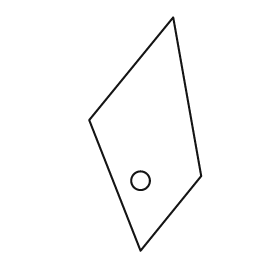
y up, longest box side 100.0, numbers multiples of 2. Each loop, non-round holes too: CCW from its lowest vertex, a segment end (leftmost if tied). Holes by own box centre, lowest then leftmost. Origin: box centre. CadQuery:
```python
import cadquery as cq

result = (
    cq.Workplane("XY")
    .moveTo(-2.0, -50.0)
    .lineTo(24.0, -18.0)
    .lineTo(12.0, 50.0)
    .lineTo(-24.0, 6.0)
    .close()
    .moveTo(-2.0, -20.0)
    .circle(4.0)
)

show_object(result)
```